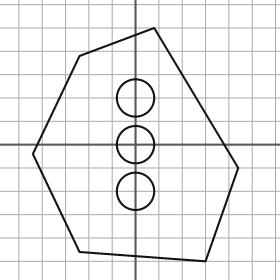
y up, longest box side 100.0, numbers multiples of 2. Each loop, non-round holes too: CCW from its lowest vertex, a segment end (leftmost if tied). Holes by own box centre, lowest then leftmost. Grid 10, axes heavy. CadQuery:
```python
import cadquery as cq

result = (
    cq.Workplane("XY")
    .moveTo(30.0, -50.0)
    .lineTo(44.0, -10.0)
    .lineTo(8.0, 50.0)
    .lineTo(-24.0, 38.0)
    .lineTo(-44.0, -4.0)
    .lineTo(-24.0, -46.0)
    .close()
    .moveTo(0.0, -20.0)
    .circle(8.0)
    .moveTo(0.0, 0.0)
    .circle(8.0)
    .moveTo(0.0, 20.0)
    .circle(8.0)
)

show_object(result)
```